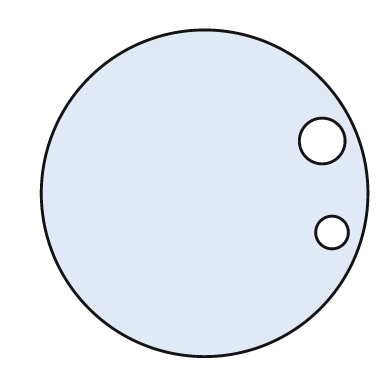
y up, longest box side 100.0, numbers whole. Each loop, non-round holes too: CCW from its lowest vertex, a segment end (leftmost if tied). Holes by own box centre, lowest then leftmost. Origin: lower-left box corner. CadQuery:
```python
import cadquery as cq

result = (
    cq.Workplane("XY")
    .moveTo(50.0, 50.0)
    .circle(50.0)
    .moveTo(89.0, 38.0)
    .circle(5.0)
    .moveTo(86.0, 66.0)
    .circle(7.0)
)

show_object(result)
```